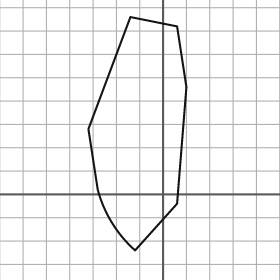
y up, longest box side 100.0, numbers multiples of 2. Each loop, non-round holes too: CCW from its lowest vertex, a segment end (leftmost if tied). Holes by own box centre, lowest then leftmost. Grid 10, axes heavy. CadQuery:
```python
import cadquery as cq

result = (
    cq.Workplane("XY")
    .moveTo(-12.0, -24.0)
    .lineTo(6.0, -4.0)
    .lineTo(10.0, 46.0)
    .lineTo(6.0, 72.0)
    .lineTo(-14.0, 76.0)
    .lineTo(-32.0, 28.0)
    .lineTo(-28.0, 2.0)
    .threePointArc((-22.0, -12.0), (-12.0, -24.0))
    .close()
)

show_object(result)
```